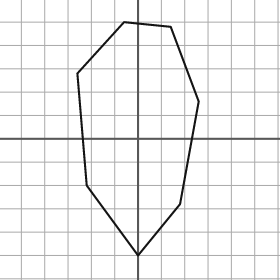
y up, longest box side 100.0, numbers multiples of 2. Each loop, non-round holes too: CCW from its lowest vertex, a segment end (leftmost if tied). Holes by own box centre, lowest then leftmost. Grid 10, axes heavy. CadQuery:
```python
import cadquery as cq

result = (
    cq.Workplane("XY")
    .moveTo(0.0, -50.0)
    .lineTo(18.0, -28.0)
    .lineTo(26.0, 16.0)
    .lineTo(14.0, 48.0)
    .lineTo(-6.0, 50.0)
    .lineTo(-26.0, 28.0)
    .lineTo(-22.0, -20.0)
    .close()
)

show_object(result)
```